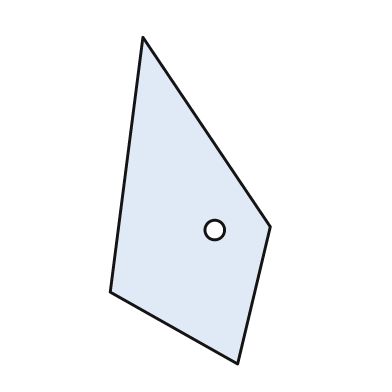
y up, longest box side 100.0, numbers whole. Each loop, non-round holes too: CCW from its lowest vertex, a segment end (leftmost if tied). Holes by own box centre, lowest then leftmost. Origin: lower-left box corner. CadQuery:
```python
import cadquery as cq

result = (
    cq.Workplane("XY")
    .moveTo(39.0, 0.0)
    .lineTo(49.0, 42.0)
    .lineTo(10.0, 100.0)
    .lineTo(0.0, 22.0)
    .close()
    .moveTo(32.0, 41.0)
    .circle(3.0)
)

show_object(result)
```